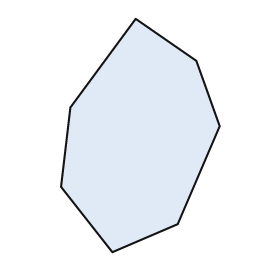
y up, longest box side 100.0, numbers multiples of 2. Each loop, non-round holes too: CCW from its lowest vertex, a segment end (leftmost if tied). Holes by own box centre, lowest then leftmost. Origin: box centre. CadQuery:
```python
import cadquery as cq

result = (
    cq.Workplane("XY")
    .moveTo(-12.0, -50.0)
    .lineTo(16.0, -38.0)
    .lineTo(34.0, 4.0)
    .lineTo(24.0, 32.0)
    .lineTo(-2.0, 50.0)
    .lineTo(-30.0, 12.0)
    .lineTo(-34.0, -22.0)
    .close()
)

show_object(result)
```